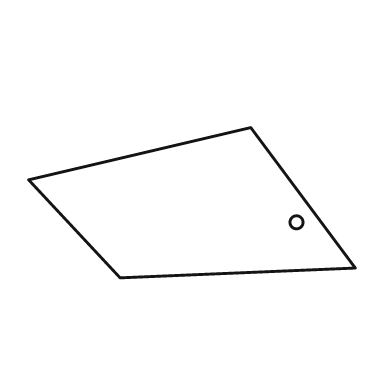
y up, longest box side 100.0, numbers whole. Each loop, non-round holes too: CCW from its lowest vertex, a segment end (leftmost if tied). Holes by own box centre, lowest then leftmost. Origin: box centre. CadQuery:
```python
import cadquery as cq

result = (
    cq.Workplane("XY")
    .moveTo(-22.0, -23.0)
    .lineTo(50.0, -20.0)
    .lineTo(18.0, 23.0)
    .lineTo(-50.0, 7.0)
    .close()
    .moveTo(32.0, -6.0)
    .circle(2.0)
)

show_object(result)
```